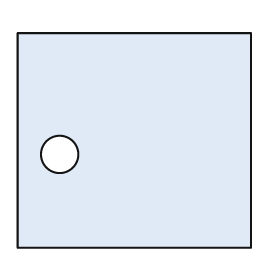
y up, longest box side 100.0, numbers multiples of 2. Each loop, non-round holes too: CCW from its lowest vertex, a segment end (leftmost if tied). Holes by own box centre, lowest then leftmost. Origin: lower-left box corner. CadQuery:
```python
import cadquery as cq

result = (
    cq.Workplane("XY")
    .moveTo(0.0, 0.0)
    .lineTo(100.0, 0.0)
    .lineTo(100.0, 92.0)
    .lineTo(0.0, 92.0)
    .close()
    .moveTo(18.0, 40.0)
    .circle(8.0)
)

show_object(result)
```